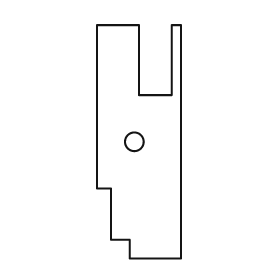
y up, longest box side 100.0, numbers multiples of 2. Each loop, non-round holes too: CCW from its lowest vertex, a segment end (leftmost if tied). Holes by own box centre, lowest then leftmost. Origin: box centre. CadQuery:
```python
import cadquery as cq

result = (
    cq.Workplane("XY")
    .moveTo(-4.0, -50.0)
    .lineTo(18.0, -50.0)
    .lineTo(18.0, 50.0)
    .lineTo(14.0, 50.0)
    .lineTo(14.0, 20.0)
    .lineTo(0.0, 20.0)
    .lineTo(0.0, 50.0)
    .lineTo(-18.0, 50.0)
    .lineTo(-18.0, -20.0)
    .lineTo(-12.0, -20.0)
    .lineTo(-12.0, -42.0)
    .lineTo(-4.0, -42.0)
    .close()
    .moveTo(-2.0, 0.0)
    .circle(4.0)
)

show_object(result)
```